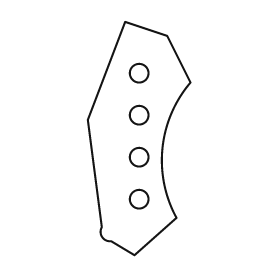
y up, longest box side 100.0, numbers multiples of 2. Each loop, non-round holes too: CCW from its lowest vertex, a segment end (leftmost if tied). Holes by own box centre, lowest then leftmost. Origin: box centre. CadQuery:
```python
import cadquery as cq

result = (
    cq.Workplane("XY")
    .moveTo(-2.0, -50.0)
    .lineTo(16.0, -34.0)
    .threePointArc((10.0, -4.0), (22.0, 24.0))
    .lineTo(12.0, 44.0)
    .lineTo(-6.0, 50.0)
    .lineTo(-22.0, 8.0)
    .lineTo(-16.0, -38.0)
    .threePointArc((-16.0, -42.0), (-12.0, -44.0))
    .close()
    .moveTo(0.0, -26.0)
    .circle(4.0)
    .moveTo(0.0, -8.0)
    .circle(4.0)
    .moveTo(0.0, 10.0)
    .circle(4.0)
    .moveTo(0.0, 28.0)
    .circle(4.0)
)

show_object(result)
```